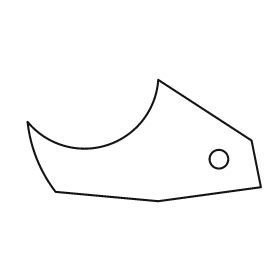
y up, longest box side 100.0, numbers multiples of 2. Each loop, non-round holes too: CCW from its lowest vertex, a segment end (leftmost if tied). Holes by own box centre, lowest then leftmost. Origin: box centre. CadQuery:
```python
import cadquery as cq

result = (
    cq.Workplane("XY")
    .moveTo(6.0, -26.0)
    .lineTo(50.0, -20.0)
    .lineTo(46.0, 0.0)
    .lineTo(6.0, 26.0)
    .threePointArc((-16.0, -2.0), (-50.0, 8.0))
    .threePointArc((-46.0, -8.0), (-38.0, -22.0))
    .close()
    .moveTo(32.0, -8.0)
    .circle(4.0)
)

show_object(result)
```